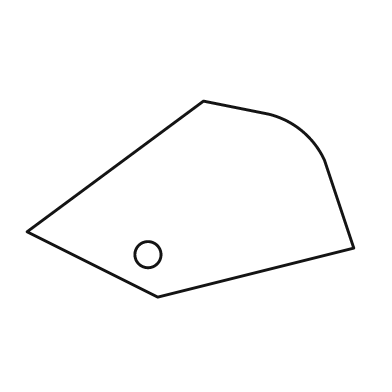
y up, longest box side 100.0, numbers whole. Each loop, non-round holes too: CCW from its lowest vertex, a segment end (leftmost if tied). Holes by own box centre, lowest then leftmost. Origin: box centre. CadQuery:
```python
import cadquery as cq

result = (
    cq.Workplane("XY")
    .moveTo(-10.0, -30.0)
    .lineTo(50.0, -15.0)
    .lineTo(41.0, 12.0)
    .threePointArc((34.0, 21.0), (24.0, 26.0))
    .lineTo(4.0, 30.0)
    .lineTo(-50.0, -10.0)
    .close()
    .moveTo(-13.0, -17.0)
    .circle(4.0)
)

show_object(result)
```